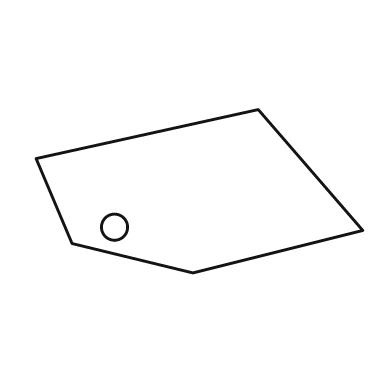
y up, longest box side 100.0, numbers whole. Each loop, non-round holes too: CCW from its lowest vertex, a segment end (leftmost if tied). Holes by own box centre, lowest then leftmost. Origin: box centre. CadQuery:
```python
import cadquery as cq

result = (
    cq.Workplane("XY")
    .moveTo(-2.0, -25.0)
    .lineTo(50.0, -12.0)
    .lineTo(18.0, 25.0)
    .lineTo(-50.0, 10.0)
    .lineTo(-39.0, -16.0)
    .close()
    .moveTo(-26.0, -11.0)
    .circle(4.0)
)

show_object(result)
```